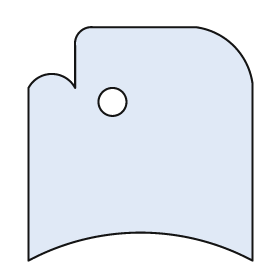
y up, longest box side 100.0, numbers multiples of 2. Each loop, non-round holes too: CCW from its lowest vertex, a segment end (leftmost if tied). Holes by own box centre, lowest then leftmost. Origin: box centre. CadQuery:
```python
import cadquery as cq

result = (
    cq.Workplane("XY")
    .moveTo(-48.0, -50.0)
    .threePointArc((0.0, -38.0), (48.0, -50.0))
    .lineTo(48.0, 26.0)
    .threePointArc((40.0, 42.0), (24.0, 50.0))
    .lineTo(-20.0, 50.0)
    .threePointArc((-26.0, 48.0), (-28.0, 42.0))
    .lineTo(-28.0, 24.0)
    .threePointArc((-38.0, 30.0), (-48.0, 24.0))
    .close()
    .moveTo(-12.0, 18.0)
    .circle(6.0)
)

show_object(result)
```